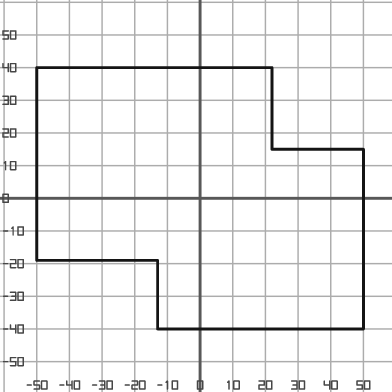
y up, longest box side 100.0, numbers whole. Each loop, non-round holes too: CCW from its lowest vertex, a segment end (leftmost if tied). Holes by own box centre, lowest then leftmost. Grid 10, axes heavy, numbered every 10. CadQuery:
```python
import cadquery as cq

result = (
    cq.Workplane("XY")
    .moveTo(-13.0, -40.0)
    .lineTo(50.0, -40.0)
    .lineTo(50.0, 15.0)
    .lineTo(22.0, 15.0)
    .lineTo(22.0, 40.0)
    .lineTo(-50.0, 40.0)
    .lineTo(-50.0, -19.0)
    .lineTo(-13.0, -19.0)
    .close()
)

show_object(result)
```